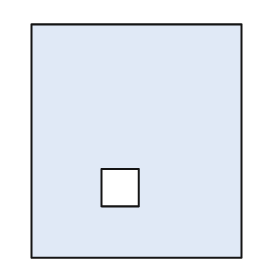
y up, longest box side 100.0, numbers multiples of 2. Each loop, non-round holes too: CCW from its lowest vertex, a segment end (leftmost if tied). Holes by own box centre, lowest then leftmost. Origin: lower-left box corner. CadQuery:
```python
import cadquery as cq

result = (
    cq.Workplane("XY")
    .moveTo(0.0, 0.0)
    .lineTo(90.0, 0.0)
    .lineTo(90.0, 100.0)
    .lineTo(0.0, 100.0)
    .close()
    .moveTo(30.0, 22.0)
    .lineTo(46.0, 22.0)
    .lineTo(46.0, 38.0)
    .lineTo(30.0, 38.0)
    .close()
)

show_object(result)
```